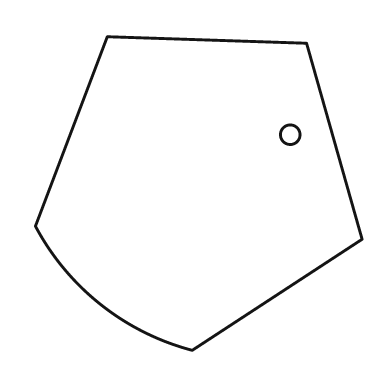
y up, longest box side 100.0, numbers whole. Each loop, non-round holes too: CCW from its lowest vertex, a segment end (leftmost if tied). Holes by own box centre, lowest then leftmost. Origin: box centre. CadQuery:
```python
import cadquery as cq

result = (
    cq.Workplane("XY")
    .moveTo(-2.0, -48.0)
    .lineTo(50.0, -14.0)
    .lineTo(33.0, 46.0)
    .lineTo(-28.0, 48.0)
    .lineTo(-50.0, -10.0)
    .threePointArc((-30.0, -34.0), (-2.0, -48.0))
    .close()
    .moveTo(28.0, 18.0)
    .circle(3.0)
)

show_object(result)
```